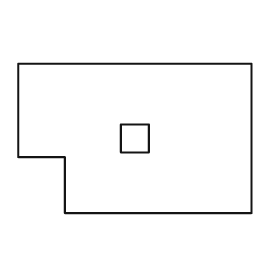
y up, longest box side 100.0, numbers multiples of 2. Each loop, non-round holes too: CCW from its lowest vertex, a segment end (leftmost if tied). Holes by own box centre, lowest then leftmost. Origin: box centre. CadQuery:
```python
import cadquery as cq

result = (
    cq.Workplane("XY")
    .moveTo(-30.0, -32.0)
    .lineTo(50.0, -32.0)
    .lineTo(50.0, 32.0)
    .lineTo(-50.0, 32.0)
    .lineTo(-50.0, -8.0)
    .lineTo(-30.0, -8.0)
    .close()
    .moveTo(-6.0, -6.0)
    .lineTo(6.0, -6.0)
    .lineTo(6.0, 6.0)
    .lineTo(-6.0, 6.0)
    .close()
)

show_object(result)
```